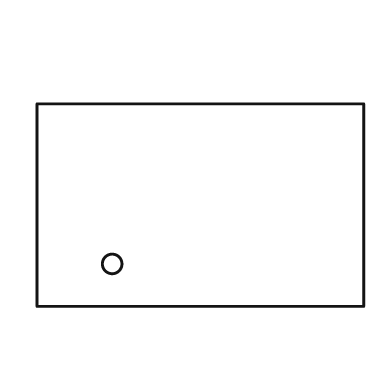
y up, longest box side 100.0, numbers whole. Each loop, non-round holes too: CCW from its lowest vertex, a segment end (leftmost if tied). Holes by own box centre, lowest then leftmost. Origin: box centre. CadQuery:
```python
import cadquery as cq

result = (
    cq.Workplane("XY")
    .moveTo(-50.0, -31.0)
    .lineTo(50.0, -31.0)
    .lineTo(50.0, 31.0)
    .lineTo(-50.0, 31.0)
    .close()
    .moveTo(-27.0, -18.0)
    .circle(3.0)
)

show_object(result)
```